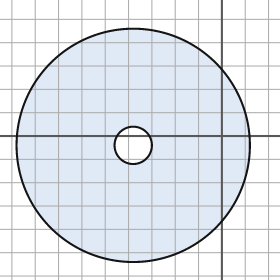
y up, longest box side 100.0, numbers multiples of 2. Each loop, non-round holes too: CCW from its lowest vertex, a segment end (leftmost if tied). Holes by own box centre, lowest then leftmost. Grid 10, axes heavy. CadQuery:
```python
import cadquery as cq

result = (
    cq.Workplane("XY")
    .moveTo(-38.0, -4.0)
    .circle(50.0)
    .moveTo(-38.0, -4.0)
    .circle(8.0)
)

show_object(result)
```